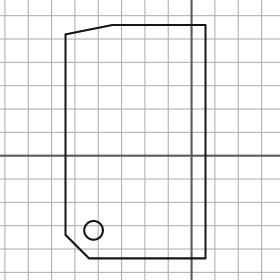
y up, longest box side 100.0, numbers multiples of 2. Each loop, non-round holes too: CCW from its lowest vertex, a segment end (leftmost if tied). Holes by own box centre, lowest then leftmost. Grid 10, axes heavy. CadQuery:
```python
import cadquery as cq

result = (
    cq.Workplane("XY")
    .moveTo(-44.0, -44.0)
    .lineTo(6.0, -44.0)
    .lineTo(6.0, 56.0)
    .lineTo(-34.0, 56.0)
    .lineTo(-54.0, 52.0)
    .lineTo(-54.0, -34.0)
    .close()
    .moveTo(-42.0, -32.0)
    .circle(4.0)
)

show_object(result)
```